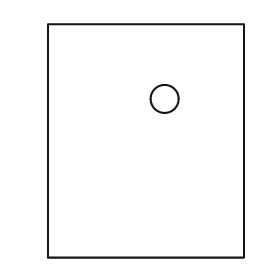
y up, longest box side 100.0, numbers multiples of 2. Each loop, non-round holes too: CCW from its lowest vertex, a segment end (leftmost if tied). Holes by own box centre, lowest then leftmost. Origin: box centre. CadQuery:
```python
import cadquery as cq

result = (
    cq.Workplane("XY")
    .moveTo(-42.0, -50.0)
    .lineTo(42.0, -50.0)
    .lineTo(42.0, 50.0)
    .lineTo(-42.0, 50.0)
    .close()
    .moveTo(8.0, 18.0)
    .circle(6.0)
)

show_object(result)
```